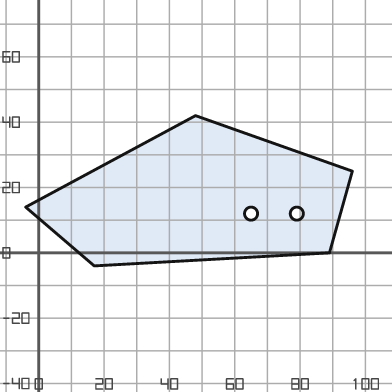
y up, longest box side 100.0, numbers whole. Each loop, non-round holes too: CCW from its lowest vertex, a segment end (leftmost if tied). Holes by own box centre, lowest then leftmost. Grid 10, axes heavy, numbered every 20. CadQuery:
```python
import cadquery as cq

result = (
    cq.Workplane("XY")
    .moveTo(17.0, -4.0)
    .lineTo(89.0, 0.0)
    .lineTo(96.0, 25.0)
    .lineTo(48.0, 42.0)
    .lineTo(-4.0, 14.0)
    .close()
    .moveTo(65.0, 12.0)
    .circle(2.0)
    .moveTo(79.0, 12.0)
    .circle(2.0)
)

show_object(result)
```